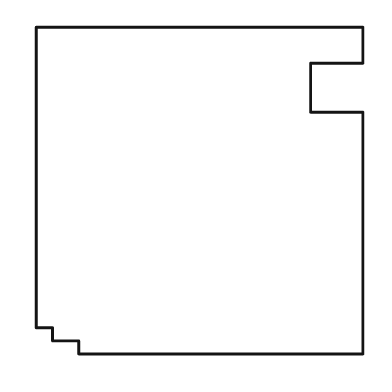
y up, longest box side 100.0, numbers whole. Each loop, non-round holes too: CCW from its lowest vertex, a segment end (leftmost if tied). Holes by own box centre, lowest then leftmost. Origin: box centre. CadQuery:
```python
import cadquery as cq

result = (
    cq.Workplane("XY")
    .moveTo(-37.0, -50.0)
    .lineTo(50.0, -50.0)
    .lineTo(50.0, 24.0)
    .lineTo(34.0, 24.0)
    .lineTo(34.0, 39.0)
    .lineTo(50.0, 39.0)
    .lineTo(50.0, 50.0)
    .lineTo(-50.0, 50.0)
    .lineTo(-50.0, -42.0)
    .lineTo(-45.0, -42.0)
    .lineTo(-45.0, -46.0)
    .lineTo(-37.0, -46.0)
    .close()
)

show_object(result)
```